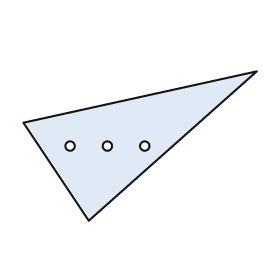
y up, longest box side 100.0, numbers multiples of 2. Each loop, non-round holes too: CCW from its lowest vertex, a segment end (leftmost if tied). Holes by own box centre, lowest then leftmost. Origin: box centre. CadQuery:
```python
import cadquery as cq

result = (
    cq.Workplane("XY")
    .moveTo(-22.0, -32.0)
    .lineTo(50.0, 32.0)
    .lineTo(-50.0, 10.0)
    .close()
    .moveTo(-30.0, 0.0)
    .circle(2.0)
    .moveTo(-14.0, 0.0)
    .circle(2.0)
    .moveTo(2.0, 0.0)
    .circle(2.0)
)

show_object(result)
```